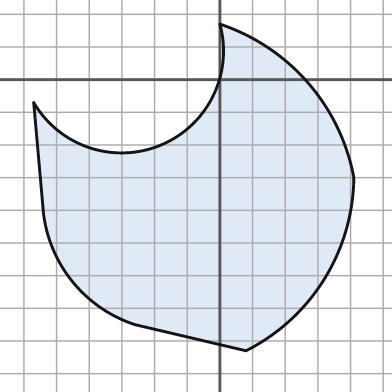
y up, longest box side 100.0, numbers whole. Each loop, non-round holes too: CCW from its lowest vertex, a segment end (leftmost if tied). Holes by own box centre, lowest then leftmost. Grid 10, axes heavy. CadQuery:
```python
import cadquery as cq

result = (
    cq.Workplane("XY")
    .moveTo(8.0, -83.0)
    .threePointArc((32.0, -61.0), (41.0, -30.0))
    .threePointArc((27.0, -1.0), (0.0, 17.0))
    .threePointArc((-18.0, -20.0), (-57.0, -7.0))
    .lineTo(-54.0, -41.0)
    .threePointArc((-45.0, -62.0), (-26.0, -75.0))
    .close()
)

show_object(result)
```